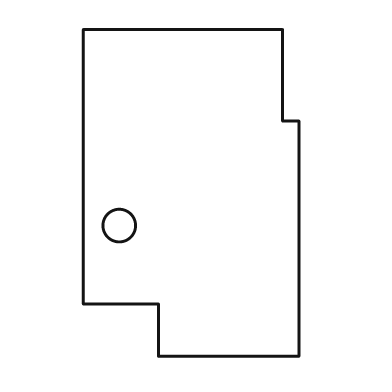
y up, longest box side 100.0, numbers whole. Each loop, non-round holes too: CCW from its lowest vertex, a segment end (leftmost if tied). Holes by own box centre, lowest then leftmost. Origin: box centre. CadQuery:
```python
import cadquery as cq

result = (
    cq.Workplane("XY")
    .moveTo(-10.0, -50.0)
    .lineTo(33.0, -50.0)
    .lineTo(33.0, 22.0)
    .lineTo(28.0, 22.0)
    .lineTo(28.0, 50.0)
    .lineTo(-33.0, 50.0)
    .lineTo(-33.0, -34.0)
    .lineTo(-10.0, -34.0)
    .close()
    .moveTo(-22.0, -10.0)
    .circle(5.0)
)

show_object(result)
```